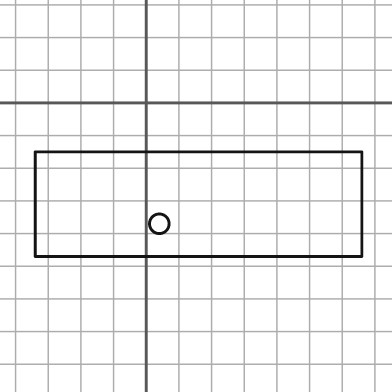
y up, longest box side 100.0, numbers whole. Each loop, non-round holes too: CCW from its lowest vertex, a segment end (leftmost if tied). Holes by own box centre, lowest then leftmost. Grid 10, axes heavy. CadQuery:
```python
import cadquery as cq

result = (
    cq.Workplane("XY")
    .moveTo(-34.0, -47.0)
    .lineTo(66.0, -47.0)
    .lineTo(66.0, -15.0)
    .lineTo(-34.0, -15.0)
    .close()
    .moveTo(4.0, -37.0)
    .circle(3.0)
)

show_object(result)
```